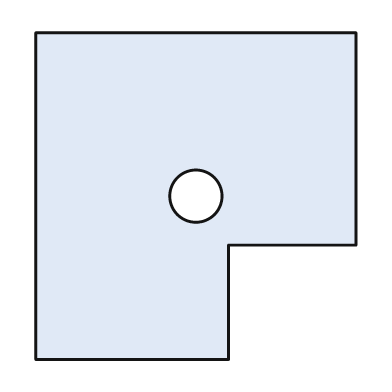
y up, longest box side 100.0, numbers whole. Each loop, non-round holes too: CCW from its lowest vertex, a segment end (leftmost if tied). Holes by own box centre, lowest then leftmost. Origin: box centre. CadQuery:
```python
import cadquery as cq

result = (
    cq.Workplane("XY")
    .moveTo(-49.0, -50.0)
    .lineTo(10.0, -50.0)
    .lineTo(10.0, -15.0)
    .lineTo(49.0, -15.0)
    .lineTo(49.0, 50.0)
    .lineTo(-49.0, 50.0)
    .close()
    .moveTo(0.0, 0.0)
    .circle(8.0)
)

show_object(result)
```